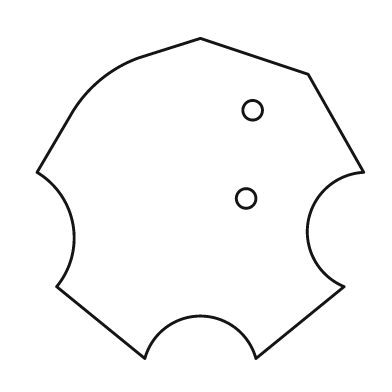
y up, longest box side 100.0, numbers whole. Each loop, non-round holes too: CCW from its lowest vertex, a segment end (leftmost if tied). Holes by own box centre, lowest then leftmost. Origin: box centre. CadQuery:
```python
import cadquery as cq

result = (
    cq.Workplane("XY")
    .moveTo(-17.0, -49.0)
    .threePointArc((0.0, -36.0), (17.0, -49.0))
    .lineTo(44.0, -27.0)
    .threePointArc((33.0, -7.0), (50.0, 8.0))
    .lineTo(33.0, 38.0)
    .lineTo(0.0, 49.0)
    .lineTo(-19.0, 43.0)
    .threePointArc((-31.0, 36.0), (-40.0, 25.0))
    .lineTo(-50.0, 8.0)
    .threePointArc((-39.0, -8.0), (-44.0, -27.0))
    .close()
    .moveTo(14.0, 0.0)
    .circle(3.0)
    .moveTo(16.0, 27.0)
    .circle(3.0)
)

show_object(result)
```